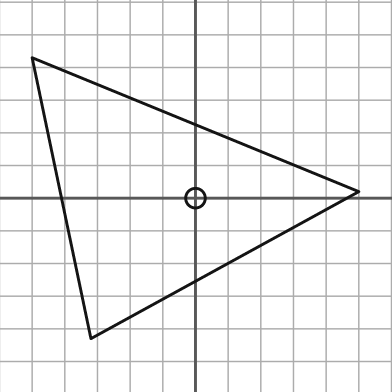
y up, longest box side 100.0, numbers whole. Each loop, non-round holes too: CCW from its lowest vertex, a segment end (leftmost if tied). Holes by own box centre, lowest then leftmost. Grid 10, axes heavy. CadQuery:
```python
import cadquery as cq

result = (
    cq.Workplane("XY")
    .moveTo(-32.0, -43.0)
    .lineTo(50.0, 2.0)
    .lineTo(-50.0, 43.0)
    .close()
    .moveTo(0.0, 0.0)
    .circle(3.0)
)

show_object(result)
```